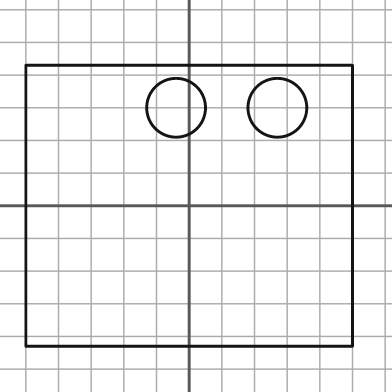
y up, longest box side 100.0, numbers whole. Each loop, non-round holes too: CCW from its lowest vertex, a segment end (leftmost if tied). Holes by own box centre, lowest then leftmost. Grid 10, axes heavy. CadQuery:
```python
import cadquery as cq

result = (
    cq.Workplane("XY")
    .moveTo(-50.0, -43.0)
    .lineTo(50.0, -43.0)
    .lineTo(50.0, 43.0)
    .lineTo(-50.0, 43.0)
    .close()
    .moveTo(-4.0, 30.0)
    .circle(9.0)
    .moveTo(27.0, 30.0)
    .circle(9.0)
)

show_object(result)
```